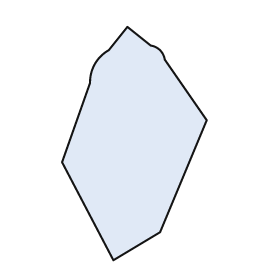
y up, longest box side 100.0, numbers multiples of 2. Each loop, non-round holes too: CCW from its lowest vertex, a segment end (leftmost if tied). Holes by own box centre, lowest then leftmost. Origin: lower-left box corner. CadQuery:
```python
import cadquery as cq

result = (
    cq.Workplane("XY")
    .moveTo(22.0, 0.0)
    .lineTo(42.0, 12.0)
    .lineTo(62.0, 60.0)
    .lineTo(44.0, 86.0)
    .threePointArc((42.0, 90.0), (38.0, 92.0))
    .lineTo(28.0, 100.0)
    .lineTo(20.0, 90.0)
    .threePointArc((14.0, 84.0), (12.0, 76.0))
    .lineTo(0.0, 42.0)
    .close()
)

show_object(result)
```